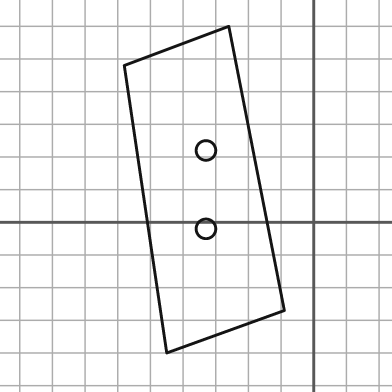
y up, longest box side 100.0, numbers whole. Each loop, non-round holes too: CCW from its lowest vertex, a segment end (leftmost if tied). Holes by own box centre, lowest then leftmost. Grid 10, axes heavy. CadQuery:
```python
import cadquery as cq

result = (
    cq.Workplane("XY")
    .moveTo(-45.0, -40.0)
    .lineTo(-9.0, -27.0)
    .lineTo(-26.0, 60.0)
    .lineTo(-58.0, 48.0)
    .close()
    .moveTo(-33.0, -2.0)
    .circle(3.0)
    .moveTo(-33.0, 22.0)
    .circle(3.0)
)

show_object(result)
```